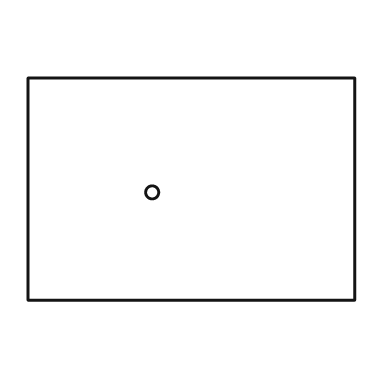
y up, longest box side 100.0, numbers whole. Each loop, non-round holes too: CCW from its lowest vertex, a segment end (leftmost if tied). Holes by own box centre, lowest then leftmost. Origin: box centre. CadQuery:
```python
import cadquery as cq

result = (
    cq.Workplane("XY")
    .moveTo(-50.0, -34.0)
    .lineTo(50.0, -34.0)
    .lineTo(50.0, 34.0)
    .lineTo(-50.0, 34.0)
    .close()
    .moveTo(-12.0, -1.0)
    .circle(2.0)
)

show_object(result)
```